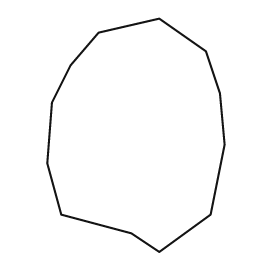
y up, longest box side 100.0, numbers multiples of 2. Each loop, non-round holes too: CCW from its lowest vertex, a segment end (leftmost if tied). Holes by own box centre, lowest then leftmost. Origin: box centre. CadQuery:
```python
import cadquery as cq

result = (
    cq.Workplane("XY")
    .moveTo(10.0, -50.0)
    .lineTo(32.0, -34.0)
    .lineTo(38.0, -4.0)
    .lineTo(36.0, 18.0)
    .lineTo(30.0, 36.0)
    .lineTo(10.0, 50.0)
    .lineTo(-16.0, 44.0)
    .lineTo(-28.0, 30.0)
    .lineTo(-36.0, 14.0)
    .lineTo(-38.0, -12.0)
    .lineTo(-32.0, -34.0)
    .lineTo(-2.0, -42.0)
    .close()
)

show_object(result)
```